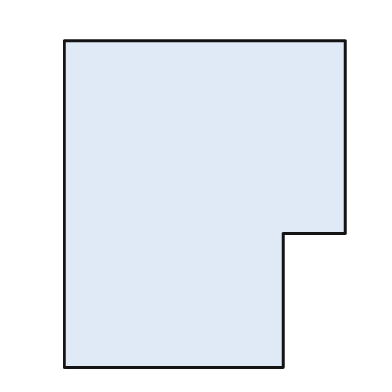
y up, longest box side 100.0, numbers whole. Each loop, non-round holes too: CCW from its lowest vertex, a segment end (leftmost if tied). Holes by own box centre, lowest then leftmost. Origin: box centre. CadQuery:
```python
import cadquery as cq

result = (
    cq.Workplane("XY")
    .moveTo(-43.0, -50.0)
    .lineTo(24.0, -50.0)
    .lineTo(24.0, -9.0)
    .lineTo(43.0, -9.0)
    .lineTo(43.0, 50.0)
    .lineTo(-43.0, 50.0)
    .close()
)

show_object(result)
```